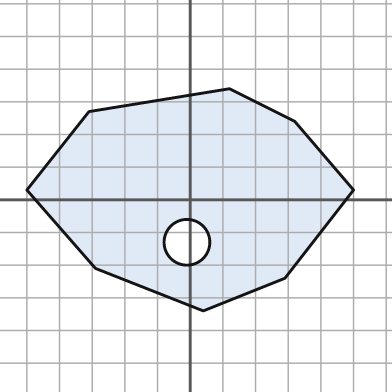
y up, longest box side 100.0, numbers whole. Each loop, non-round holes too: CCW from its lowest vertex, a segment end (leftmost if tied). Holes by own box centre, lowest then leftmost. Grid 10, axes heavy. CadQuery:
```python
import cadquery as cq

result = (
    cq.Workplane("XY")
    .moveTo(4.0, -34.0)
    .lineTo(29.0, -24.0)
    .lineTo(50.0, 3.0)
    .lineTo(32.0, 24.0)
    .lineTo(12.0, 34.0)
    .lineTo(-31.0, 27.0)
    .lineTo(-50.0, 3.0)
    .lineTo(-29.0, -21.0)
    .close()
    .moveTo(-1.0, -13.0)
    .circle(7.0)
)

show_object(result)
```